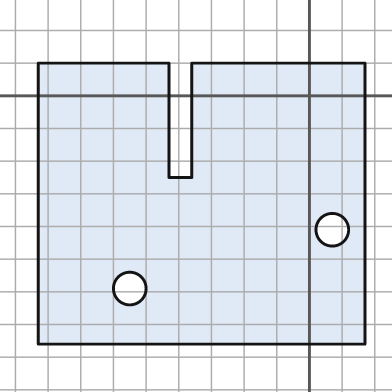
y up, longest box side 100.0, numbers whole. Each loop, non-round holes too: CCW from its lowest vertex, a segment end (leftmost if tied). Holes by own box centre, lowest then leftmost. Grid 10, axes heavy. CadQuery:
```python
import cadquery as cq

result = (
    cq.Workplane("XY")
    .moveTo(-83.0, -76.0)
    .lineTo(17.0, -76.0)
    .lineTo(17.0, 10.0)
    .lineTo(-36.0, 10.0)
    .lineTo(-36.0, -25.0)
    .lineTo(-43.0, -25.0)
    .lineTo(-43.0, 10.0)
    .lineTo(-83.0, 10.0)
    .close()
    .moveTo(-55.0, -59.0)
    .circle(5.0)
    .moveTo(7.0, -41.0)
    .circle(5.0)
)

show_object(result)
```